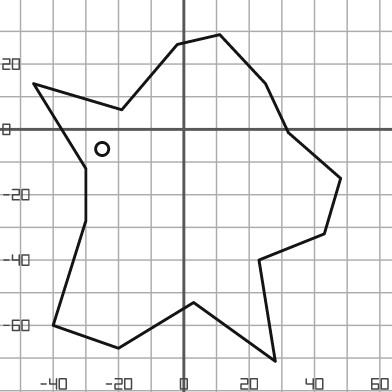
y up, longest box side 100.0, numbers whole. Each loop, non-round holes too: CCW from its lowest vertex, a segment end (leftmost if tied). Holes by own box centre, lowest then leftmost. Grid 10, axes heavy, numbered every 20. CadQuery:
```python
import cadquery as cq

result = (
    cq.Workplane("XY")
    .moveTo(28.0, -71.0)
    .lineTo(23.0, -40.0)
    .lineTo(43.0, -32.0)
    .lineTo(48.0, -15.0)
    .lineTo(32.0, -1.0)
    .lineTo(25.0, 14.0)
    .lineTo(11.0, 29.0)
    .lineTo(-2.0, 26.0)
    .lineTo(-19.0, 6.0)
    .lineTo(-46.0, 14.0)
    .lineTo(-30.0, -12.0)
    .lineTo(-30.0, -28.0)
    .lineTo(-40.0, -60.0)
    .lineTo(-20.0, -67.0)
    .lineTo(3.0, -53.0)
    .close()
    .moveTo(-25.0, -6.0)
    .circle(2.0)
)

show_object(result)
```